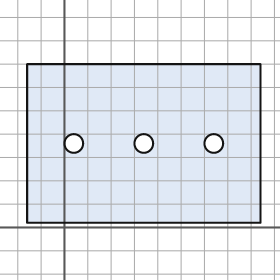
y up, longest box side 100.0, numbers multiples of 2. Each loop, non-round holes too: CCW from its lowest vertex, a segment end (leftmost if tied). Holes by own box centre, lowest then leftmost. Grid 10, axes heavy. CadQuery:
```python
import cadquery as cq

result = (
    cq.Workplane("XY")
    .moveTo(-16.0, 2.0)
    .lineTo(84.0, 2.0)
    .lineTo(84.0, 70.0)
    .lineTo(-16.0, 70.0)
    .close()
    .moveTo(4.0, 36.0)
    .circle(4.0)
    .moveTo(34.0, 36.0)
    .circle(4.0)
    .moveTo(64.0, 36.0)
    .circle(4.0)
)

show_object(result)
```